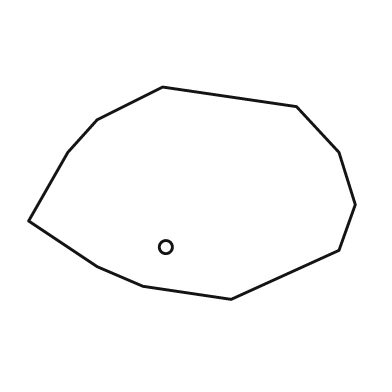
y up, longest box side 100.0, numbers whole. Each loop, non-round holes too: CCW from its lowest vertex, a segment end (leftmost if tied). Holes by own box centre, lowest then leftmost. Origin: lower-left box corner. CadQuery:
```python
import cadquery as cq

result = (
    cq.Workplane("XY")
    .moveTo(62.0, 0.0)
    .lineTo(95.0, 15.0)
    .lineTo(100.0, 29.0)
    .lineTo(95.0, 45.0)
    .lineTo(82.0, 59.0)
    .lineTo(41.0, 65.0)
    .lineTo(21.0, 55.0)
    .lineTo(12.0, 45.0)
    .lineTo(0.0, 24.0)
    .lineTo(21.0, 10.0)
    .lineTo(35.0, 4.0)
    .close()
    .moveTo(42.0, 16.0)
    .circle(2.0)
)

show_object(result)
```